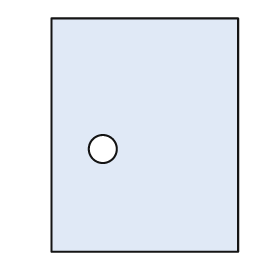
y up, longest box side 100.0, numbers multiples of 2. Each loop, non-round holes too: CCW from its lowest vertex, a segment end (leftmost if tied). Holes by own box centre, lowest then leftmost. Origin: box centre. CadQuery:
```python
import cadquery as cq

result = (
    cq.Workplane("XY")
    .moveTo(-40.0, -50.0)
    .lineTo(40.0, -50.0)
    .lineTo(40.0, 50.0)
    .lineTo(-40.0, 50.0)
    .close()
    .moveTo(-18.0, -6.0)
    .circle(6.0)
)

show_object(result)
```